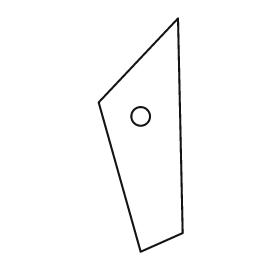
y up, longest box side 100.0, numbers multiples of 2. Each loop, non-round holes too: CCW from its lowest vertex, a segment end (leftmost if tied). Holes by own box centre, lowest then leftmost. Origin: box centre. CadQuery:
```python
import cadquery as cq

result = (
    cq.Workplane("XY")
    .moveTo(0.0, -50.0)
    .lineTo(18.0, -42.0)
    .lineTo(16.0, 50.0)
    .lineTo(-18.0, 14.0)
    .close()
    .moveTo(0.0, 8.0)
    .circle(4.0)
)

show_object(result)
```